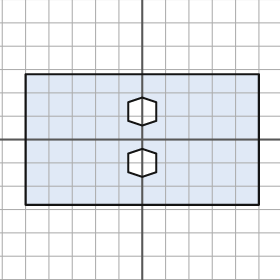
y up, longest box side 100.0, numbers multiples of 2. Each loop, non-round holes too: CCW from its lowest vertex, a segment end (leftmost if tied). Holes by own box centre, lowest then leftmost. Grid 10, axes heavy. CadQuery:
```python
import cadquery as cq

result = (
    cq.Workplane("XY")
    .moveTo(-50.0, -28.0)
    .lineTo(50.0, -28.0)
    .lineTo(50.0, 28.0)
    .lineTo(-50.0, 28.0)
    .close()
    .moveTo(0.0, -16.0)
    .lineTo(6.0, -14.0)
    .lineTo(6.0, -6.0)
    .lineTo(0.0, -4.0)
    .lineTo(-6.0, -6.0)
    .lineTo(-6.0, -14.0)
    .close()
    .moveTo(0.0, 6.0)
    .lineTo(6.0, 8.0)
    .lineTo(6.0, 16.0)
    .lineTo(0.0, 18.0)
    .lineTo(-6.0, 16.0)
    .lineTo(-6.0, 8.0)
    .close()
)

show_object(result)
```